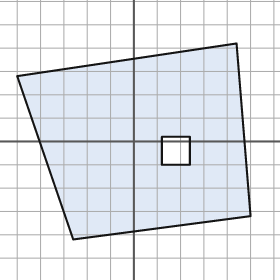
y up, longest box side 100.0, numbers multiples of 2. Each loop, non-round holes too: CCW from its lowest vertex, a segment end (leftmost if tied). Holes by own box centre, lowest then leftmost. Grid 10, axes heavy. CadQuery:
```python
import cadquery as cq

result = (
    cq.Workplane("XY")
    .moveTo(-26.0, -42.0)
    .lineTo(50.0, -32.0)
    .lineTo(44.0, 42.0)
    .lineTo(-50.0, 28.0)
    .close()
    .moveTo(12.0, -10.0)
    .lineTo(24.0, -10.0)
    .lineTo(24.0, 2.0)
    .lineTo(12.0, 2.0)
    .close()
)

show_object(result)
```